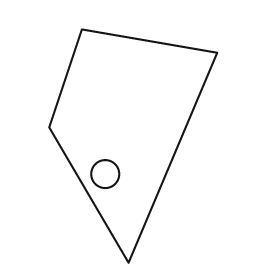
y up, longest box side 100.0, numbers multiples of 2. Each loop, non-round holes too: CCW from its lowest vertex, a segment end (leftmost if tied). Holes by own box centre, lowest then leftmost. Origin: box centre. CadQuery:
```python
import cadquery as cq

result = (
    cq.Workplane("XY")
    .moveTo(-2.0, -50.0)
    .lineTo(36.0, 40.0)
    .lineTo(-22.0, 50.0)
    .lineTo(-36.0, 8.0)
    .close()
    .moveTo(-12.0, -12.0)
    .circle(6.0)
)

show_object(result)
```